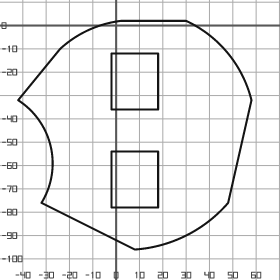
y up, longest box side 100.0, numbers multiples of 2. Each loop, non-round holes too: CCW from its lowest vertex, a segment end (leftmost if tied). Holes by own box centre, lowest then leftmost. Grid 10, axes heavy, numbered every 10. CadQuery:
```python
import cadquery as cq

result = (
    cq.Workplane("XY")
    .moveTo(8.0, -96.0)
    .threePointArc((30.0, -90.0), (48.0, -76.0))
    .lineTo(58.0, -32.0)
    .threePointArc((48.0, -12.0), (30.0, 2.0))
    .lineTo(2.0, 2.0)
    .threePointArc((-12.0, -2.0), (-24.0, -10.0))
    .lineTo(-42.0, -32.0)
    .threePointArc((-28.0, -52.0), (-32.0, -76.0))
    .close()
    .moveTo(-2.0, -78.0)
    .lineTo(18.0, -78.0)
    .lineTo(18.0, -54.0)
    .lineTo(-2.0, -54.0)
    .close()
    .moveTo(-2.0, -36.0)
    .lineTo(18.0, -36.0)
    .lineTo(18.0, -12.0)
    .lineTo(-2.0, -12.0)
    .close()
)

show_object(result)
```